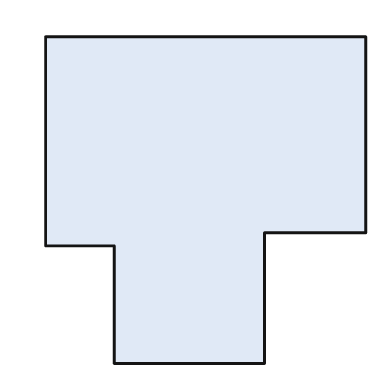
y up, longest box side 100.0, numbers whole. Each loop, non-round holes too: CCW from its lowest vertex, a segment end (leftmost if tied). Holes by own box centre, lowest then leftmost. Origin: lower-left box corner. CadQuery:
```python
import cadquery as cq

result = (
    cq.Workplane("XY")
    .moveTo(21.0, 0.0)
    .lineTo(67.0, 0.0)
    .lineTo(67.0, 40.0)
    .lineTo(98.0, 40.0)
    .lineTo(98.0, 100.0)
    .lineTo(0.0, 100.0)
    .lineTo(0.0, 36.0)
    .lineTo(21.0, 36.0)
    .close()
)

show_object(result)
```